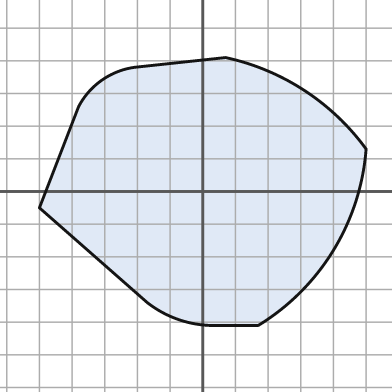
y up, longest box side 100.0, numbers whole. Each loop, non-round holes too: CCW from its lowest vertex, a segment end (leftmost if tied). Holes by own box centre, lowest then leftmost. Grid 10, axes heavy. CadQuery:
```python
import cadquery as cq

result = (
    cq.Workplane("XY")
    .moveTo(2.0, -41.0)
    .lineTo(17.0, -41.0)
    .threePointArc((40.0, -18.0), (50.0, 13.0))
    .threePointArc((31.0, 31.0), (7.0, 41.0))
    .lineTo(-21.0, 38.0)
    .threePointArc((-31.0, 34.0), (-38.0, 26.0))
    .lineTo(-50.0, -5.0)
    .lineTo(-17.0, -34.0)
    .threePointArc((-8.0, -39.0), (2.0, -41.0))
    .close()
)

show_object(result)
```